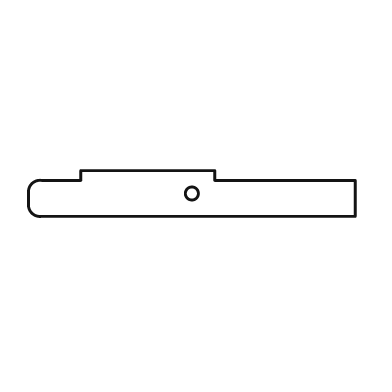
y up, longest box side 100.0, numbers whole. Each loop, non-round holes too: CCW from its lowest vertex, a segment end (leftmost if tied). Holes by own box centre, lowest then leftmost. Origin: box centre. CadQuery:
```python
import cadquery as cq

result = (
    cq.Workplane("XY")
    .moveTo(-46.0, -7.0)
    .lineTo(50.0, -7.0)
    .lineTo(50.0, 4.0)
    .lineTo(7.0, 4.0)
    .lineTo(7.0, 7.0)
    .lineTo(-34.0, 7.0)
    .lineTo(-34.0, 4.0)
    .lineTo(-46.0, 4.0)
    .threePointArc((-49.0, 3.0), (-50.0, 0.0))
    .lineTo(-50.0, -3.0)
    .threePointArc((-49.0, -6.0), (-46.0, -7.0))
    .close()
    .moveTo(0.0, 0.0)
    .circle(2.0)
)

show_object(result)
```